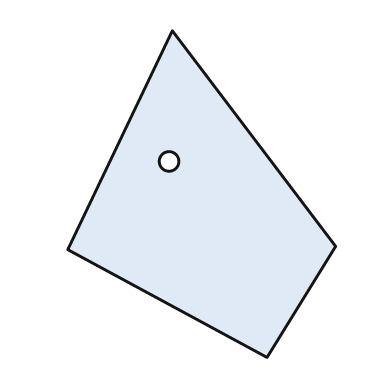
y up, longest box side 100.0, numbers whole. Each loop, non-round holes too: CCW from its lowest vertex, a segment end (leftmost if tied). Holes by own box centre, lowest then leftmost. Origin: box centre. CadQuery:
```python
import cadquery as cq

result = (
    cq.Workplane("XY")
    .moveTo(20.0, -50.0)
    .lineTo(41.0, -16.0)
    .lineTo(-9.0, 50.0)
    .lineTo(-41.0, -17.0)
    .close()
    .moveTo(-10.0, 10.0)
    .circle(3.0)
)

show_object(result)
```